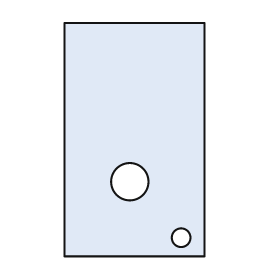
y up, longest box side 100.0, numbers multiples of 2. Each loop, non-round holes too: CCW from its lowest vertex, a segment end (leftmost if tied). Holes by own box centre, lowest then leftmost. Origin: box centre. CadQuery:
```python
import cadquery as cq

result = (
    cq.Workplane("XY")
    .moveTo(-30.0, -50.0)
    .lineTo(30.0, -50.0)
    .lineTo(30.0, 50.0)
    .lineTo(-30.0, 50.0)
    .close()
    .moveTo(20.0, -42.0)
    .circle(4.0)
    .moveTo(-2.0, -18.0)
    .circle(8.0)
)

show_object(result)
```